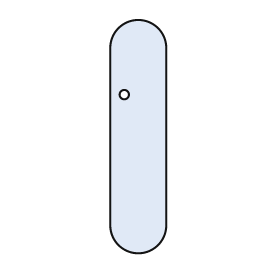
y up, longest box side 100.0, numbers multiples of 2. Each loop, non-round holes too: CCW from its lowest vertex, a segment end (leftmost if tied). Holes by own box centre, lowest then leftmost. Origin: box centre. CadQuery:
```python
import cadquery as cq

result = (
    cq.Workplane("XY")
    .moveTo(-12.0, -38.0)
    .threePointArc((0.0, -50.0), (12.0, -38.0))
    .lineTo(12.0, 38.0)
    .threePointArc((0.0, 50.0), (-12.0, 38.0))
    .close()
    .moveTo(-6.0, 18.0)
    .circle(2.0)
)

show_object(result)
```